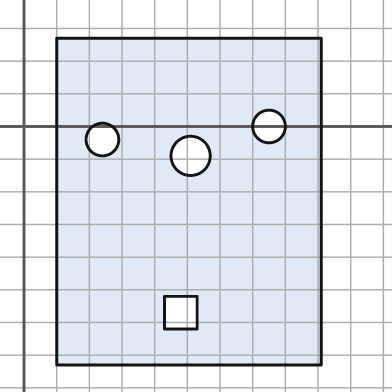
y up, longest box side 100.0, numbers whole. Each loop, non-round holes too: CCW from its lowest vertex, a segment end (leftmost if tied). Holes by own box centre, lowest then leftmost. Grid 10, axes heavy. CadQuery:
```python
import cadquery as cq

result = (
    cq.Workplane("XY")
    .moveTo(10.0, -73.0)
    .lineTo(91.0, -73.0)
    .lineTo(91.0, 27.0)
    .lineTo(10.0, 27.0)
    .close()
    .moveTo(43.0, -62.0)
    .lineTo(53.0, -62.0)
    .lineTo(53.0, -52.0)
    .lineTo(43.0, -52.0)
    .close()
    .moveTo(51.0, -9.0)
    .circle(6.0)
    .moveTo(24.0, -4.0)
    .circle(5.0)
    .moveTo(75.0, 0.0)
    .circle(5.0)
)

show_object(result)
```